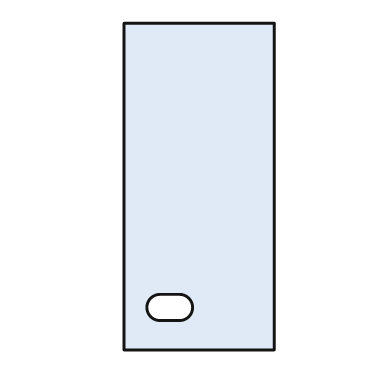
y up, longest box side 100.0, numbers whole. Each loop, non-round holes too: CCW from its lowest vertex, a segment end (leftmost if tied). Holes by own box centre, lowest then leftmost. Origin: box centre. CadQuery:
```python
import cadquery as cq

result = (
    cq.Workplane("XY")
    .moveTo(-23.0, -50.0)
    .lineTo(23.0, -50.0)
    .lineTo(23.0, 50.0)
    .lineTo(-23.0, 50.0)
    .close()
    .moveTo(-12.0, -41.0)
    .lineTo(-6.0, -41.0)
    .threePointArc((-2.0, -37.0), (-6.0, -33.0))
    .lineTo(-12.0, -33.0)
    .threePointArc((-16.0, -37.0), (-12.0, -41.0))
    .close()
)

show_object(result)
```